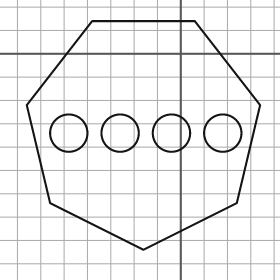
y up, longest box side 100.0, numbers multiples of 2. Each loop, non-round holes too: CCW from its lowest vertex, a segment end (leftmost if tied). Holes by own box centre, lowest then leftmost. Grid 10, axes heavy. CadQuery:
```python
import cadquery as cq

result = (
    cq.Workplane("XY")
    .moveTo(-16.0, -84.0)
    .lineTo(24.0, -64.0)
    .lineTo(34.0, -22.0)
    .lineTo(6.0, 14.0)
    .lineTo(-38.0, 14.0)
    .lineTo(-66.0, -22.0)
    .lineTo(-56.0, -64.0)
    .close()
    .moveTo(-48.0, -34.0)
    .circle(8.0)
    .moveTo(-26.0, -34.0)
    .circle(8.0)
    .moveTo(-4.0, -34.0)
    .circle(8.0)
    .moveTo(18.0, -34.0)
    .circle(8.0)
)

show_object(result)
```